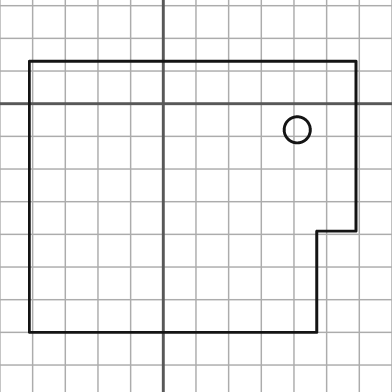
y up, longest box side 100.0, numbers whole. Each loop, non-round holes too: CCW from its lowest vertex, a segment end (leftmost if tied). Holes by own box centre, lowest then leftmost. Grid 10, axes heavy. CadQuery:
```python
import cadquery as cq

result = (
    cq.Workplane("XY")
    .moveTo(-41.0, -70.0)
    .lineTo(47.0, -70.0)
    .lineTo(47.0, -39.0)
    .lineTo(59.0, -39.0)
    .lineTo(59.0, 13.0)
    .lineTo(-41.0, 13.0)
    .close()
    .moveTo(41.0, -8.0)
    .circle(4.0)
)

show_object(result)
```